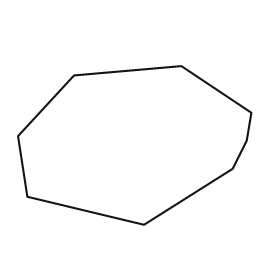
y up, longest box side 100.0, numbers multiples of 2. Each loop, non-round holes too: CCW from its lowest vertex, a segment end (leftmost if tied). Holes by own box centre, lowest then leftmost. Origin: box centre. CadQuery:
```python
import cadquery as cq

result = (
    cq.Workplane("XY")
    .moveTo(4.0, -34.0)
    .lineTo(42.0, -10.0)
    .lineTo(48.0, 2.0)
    .lineTo(50.0, 14.0)
    .lineTo(20.0, 34.0)
    .lineTo(-26.0, 30.0)
    .lineTo(-50.0, 4.0)
    .lineTo(-46.0, -22.0)
    .close()
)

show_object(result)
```